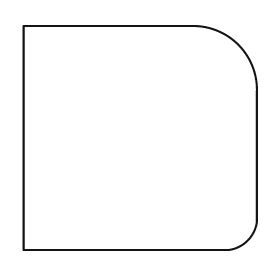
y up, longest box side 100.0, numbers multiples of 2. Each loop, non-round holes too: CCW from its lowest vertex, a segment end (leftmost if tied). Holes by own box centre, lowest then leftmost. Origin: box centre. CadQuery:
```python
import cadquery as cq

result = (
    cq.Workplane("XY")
    .moveTo(-50.0, -48.0)
    .lineTo(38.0, -48.0)
    .threePointArc((46.0, -44.0), (50.0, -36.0))
    .lineTo(50.0, 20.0)
    .threePointArc((42.0, 40.0), (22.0, 48.0))
    .lineTo(-50.0, 48.0)
    .close()
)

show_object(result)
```